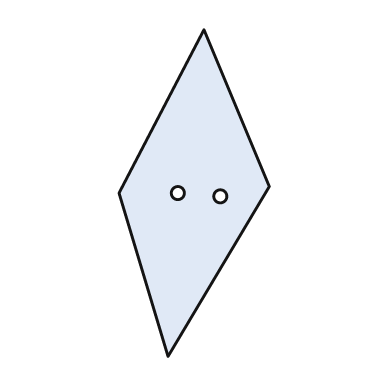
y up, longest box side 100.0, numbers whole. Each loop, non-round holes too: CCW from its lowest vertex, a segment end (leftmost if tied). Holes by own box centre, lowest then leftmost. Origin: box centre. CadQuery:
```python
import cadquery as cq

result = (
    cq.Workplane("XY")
    .moveTo(-8.0, -50.0)
    .lineTo(23.0, 2.0)
    .lineTo(3.0, 50.0)
    .lineTo(-23.0, 0.0)
    .close()
    .moveTo(8.0, -1.0)
    .circle(2.0)
    .moveTo(-5.0, 0.0)
    .circle(2.0)
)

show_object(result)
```